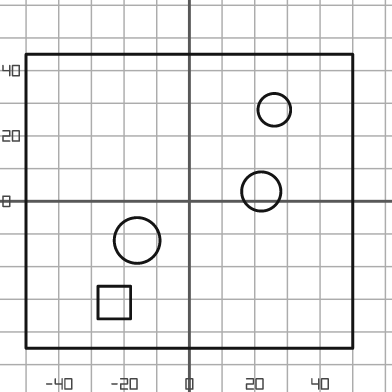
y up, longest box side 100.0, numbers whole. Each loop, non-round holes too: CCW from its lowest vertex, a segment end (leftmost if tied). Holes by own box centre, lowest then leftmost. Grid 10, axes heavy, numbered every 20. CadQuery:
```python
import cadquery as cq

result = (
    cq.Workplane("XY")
    .moveTo(-50.0, -45.0)
    .lineTo(50.0, -45.0)
    .lineTo(50.0, 45.0)
    .lineTo(-50.0, 45.0)
    .close()
    .moveTo(-28.0, -36.0)
    .lineTo(-18.0, -36.0)
    .lineTo(-18.0, -26.0)
    .lineTo(-28.0, -26.0)
    .close()
    .moveTo(-16.0, -12.0)
    .circle(7.0)
    .moveTo(22.0, 3.0)
    .circle(6.0)
    .moveTo(26.0, 28.0)
    .circle(5.0)
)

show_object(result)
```